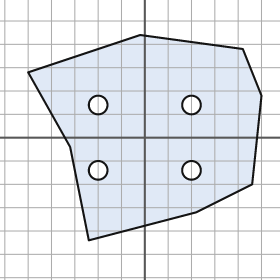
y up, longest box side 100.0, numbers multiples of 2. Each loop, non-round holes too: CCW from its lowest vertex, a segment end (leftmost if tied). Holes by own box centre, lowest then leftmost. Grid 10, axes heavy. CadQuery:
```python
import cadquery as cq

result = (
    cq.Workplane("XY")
    .moveTo(-24.0, -44.0)
    .lineTo(22.0, -32.0)
    .lineTo(46.0, -20.0)
    .lineTo(50.0, 18.0)
    .lineTo(42.0, 38.0)
    .lineTo(-2.0, 44.0)
    .lineTo(-50.0, 28.0)
    .lineTo(-32.0, -4.0)
    .close()
    .moveTo(-20.0, -14.0)
    .circle(4.0)
    .moveTo(20.0, -14.0)
    .circle(4.0)
    .moveTo(-20.0, 14.0)
    .circle(4.0)
    .moveTo(20.0, 14.0)
    .circle(4.0)
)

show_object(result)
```